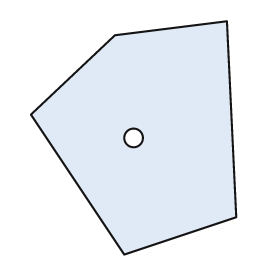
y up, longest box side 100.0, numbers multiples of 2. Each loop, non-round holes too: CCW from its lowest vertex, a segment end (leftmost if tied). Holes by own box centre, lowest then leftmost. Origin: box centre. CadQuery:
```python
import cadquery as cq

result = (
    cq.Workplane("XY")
    .moveTo(-4.0, -50.0)
    .lineTo(44.0, -34.0)
    .lineTo(40.0, 50.0)
    .lineTo(-8.0, 44.0)
    .lineTo(-44.0, 10.0)
    .close()
    .moveTo(0.0, 0.0)
    .circle(4.0)
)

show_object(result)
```